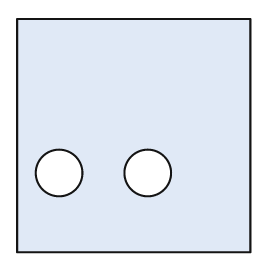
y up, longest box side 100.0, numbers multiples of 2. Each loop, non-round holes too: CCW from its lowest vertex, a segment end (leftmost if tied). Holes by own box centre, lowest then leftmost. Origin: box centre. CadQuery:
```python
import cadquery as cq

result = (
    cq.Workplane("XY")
    .moveTo(-50.0, -50.0)
    .lineTo(50.0, -50.0)
    .lineTo(50.0, 50.0)
    .lineTo(-50.0, 50.0)
    .close()
    .moveTo(-32.0, -16.0)
    .circle(10.0)
    .moveTo(6.0, -16.0)
    .circle(10.0)
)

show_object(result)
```